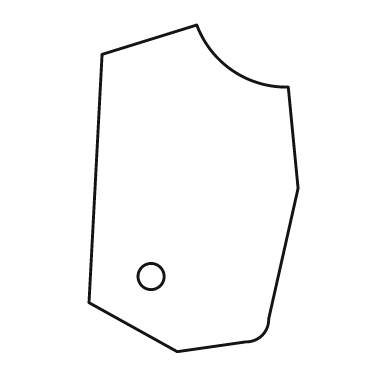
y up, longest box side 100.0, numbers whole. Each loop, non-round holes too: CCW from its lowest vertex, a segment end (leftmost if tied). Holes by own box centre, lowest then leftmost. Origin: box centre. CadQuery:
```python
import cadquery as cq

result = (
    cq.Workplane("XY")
    .moveTo(-5.0, -50.0)
    .lineTo(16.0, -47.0)
    .threePointArc((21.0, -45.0), (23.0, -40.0))
    .lineTo(32.0, 0.0)
    .lineTo(29.0, 31.0)
    .threePointArc((12.0, 36.0), (1.0, 50.0))
    .lineTo(-28.0, 41.0)
    .lineTo(-32.0, -35.0)
    .close()
    .moveTo(-13.0, -27.0)
    .circle(4.0)
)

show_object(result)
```